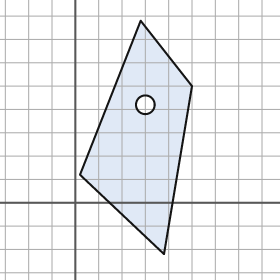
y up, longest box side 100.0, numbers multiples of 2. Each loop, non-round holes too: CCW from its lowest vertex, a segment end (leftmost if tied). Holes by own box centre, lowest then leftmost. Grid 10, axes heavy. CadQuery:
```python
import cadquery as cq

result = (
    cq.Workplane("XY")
    .moveTo(38.0, -22.0)
    .lineTo(50.0, 50.0)
    .lineTo(28.0, 78.0)
    .lineTo(2.0, 12.0)
    .close()
    .moveTo(30.0, 42.0)
    .circle(4.0)
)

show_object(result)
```